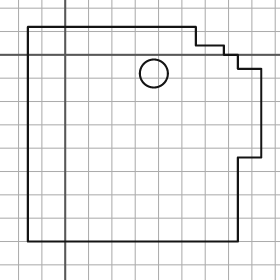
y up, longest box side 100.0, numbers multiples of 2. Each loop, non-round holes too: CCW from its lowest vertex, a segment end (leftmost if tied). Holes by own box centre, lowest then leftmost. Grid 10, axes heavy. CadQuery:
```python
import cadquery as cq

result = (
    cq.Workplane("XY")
    .moveTo(-16.0, -80.0)
    .lineTo(74.0, -80.0)
    .lineTo(74.0, -44.0)
    .lineTo(84.0, -44.0)
    .lineTo(84.0, -6.0)
    .lineTo(74.0, -6.0)
    .lineTo(74.0, 0.0)
    .lineTo(68.0, 0.0)
    .lineTo(68.0, 4.0)
    .lineTo(56.0, 4.0)
    .lineTo(56.0, 12.0)
    .lineTo(-16.0, 12.0)
    .close()
    .moveTo(38.0, -8.0)
    .circle(6.0)
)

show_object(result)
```